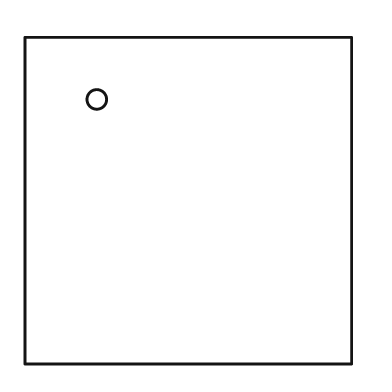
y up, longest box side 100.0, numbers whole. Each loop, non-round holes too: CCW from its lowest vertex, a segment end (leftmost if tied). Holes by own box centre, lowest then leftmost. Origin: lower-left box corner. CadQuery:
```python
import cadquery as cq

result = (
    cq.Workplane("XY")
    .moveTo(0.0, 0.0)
    .lineTo(100.0, 0.0)
    .lineTo(100.0, 100.0)
    .lineTo(0.0, 100.0)
    .close()
    .moveTo(22.0, 81.0)
    .circle(3.0)
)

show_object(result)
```